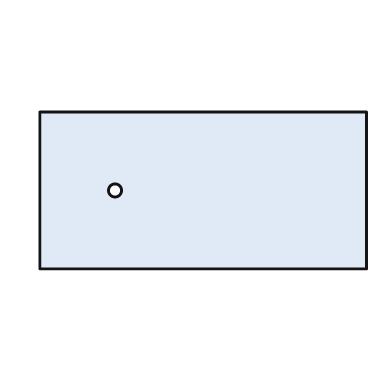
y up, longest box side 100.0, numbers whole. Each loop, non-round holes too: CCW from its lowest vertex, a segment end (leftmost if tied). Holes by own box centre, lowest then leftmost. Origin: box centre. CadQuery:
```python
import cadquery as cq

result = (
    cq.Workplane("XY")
    .moveTo(-50.0, -24.0)
    .lineTo(50.0, -24.0)
    .lineTo(50.0, 24.0)
    .lineTo(-50.0, 24.0)
    .close()
    .moveTo(-27.0, 0.0)
    .circle(2.0)
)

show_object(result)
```